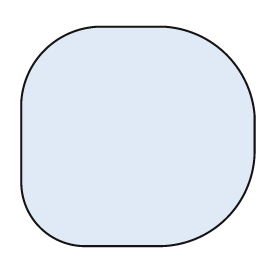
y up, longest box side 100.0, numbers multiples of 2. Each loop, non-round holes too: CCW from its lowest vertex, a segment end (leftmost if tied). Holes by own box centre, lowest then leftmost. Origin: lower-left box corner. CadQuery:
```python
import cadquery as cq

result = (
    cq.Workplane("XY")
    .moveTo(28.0, 0.0)
    .lineTo(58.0, 0.0)
    .threePointArc((88.0, 12.0), (100.0, 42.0))
    .lineTo(100.0, 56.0)
    .threePointArc((88.0, 82.0), (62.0, 94.0))
    .lineTo(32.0, 94.0)
    .threePointArc((10.0, 84.0), (0.0, 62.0))
    .lineTo(0.0, 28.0)
    .threePointArc((8.0, 8.0), (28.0, 0.0))
    .close()
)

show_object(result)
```